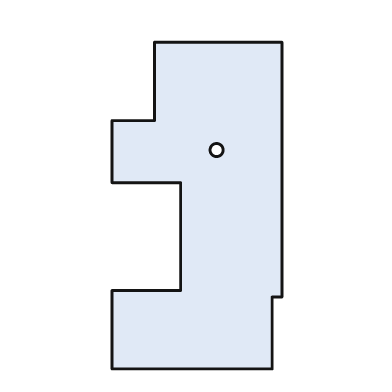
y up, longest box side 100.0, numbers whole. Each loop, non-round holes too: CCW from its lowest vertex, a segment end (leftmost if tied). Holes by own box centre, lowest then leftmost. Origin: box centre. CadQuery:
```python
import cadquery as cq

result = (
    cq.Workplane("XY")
    .moveTo(-26.0, -50.0)
    .lineTo(23.0, -50.0)
    .lineTo(23.0, -28.0)
    .lineTo(26.0, -28.0)
    .lineTo(26.0, 50.0)
    .lineTo(-13.0, 50.0)
    .lineTo(-13.0, 26.0)
    .lineTo(-26.0, 26.0)
    .lineTo(-26.0, 7.0)
    .lineTo(-5.0, 7.0)
    .lineTo(-5.0, -26.0)
    .lineTo(-26.0, -26.0)
    .close()
    .moveTo(6.0, 17.0)
    .circle(2.0)
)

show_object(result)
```